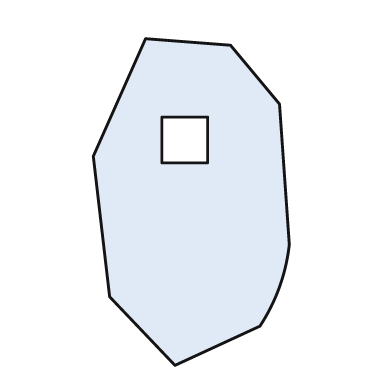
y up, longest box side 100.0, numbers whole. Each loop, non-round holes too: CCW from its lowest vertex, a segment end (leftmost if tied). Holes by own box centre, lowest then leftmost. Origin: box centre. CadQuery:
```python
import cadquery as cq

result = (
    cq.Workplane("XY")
    .moveTo(-5.0, -50.0)
    .lineTo(21.0, -38.0)
    .threePointArc((27.0, -26.0), (30.0, -13.0))
    .lineTo(27.0, 30.0)
    .lineTo(12.0, 48.0)
    .lineTo(-14.0, 50.0)
    .lineTo(-30.0, 14.0)
    .lineTo(-25.0, -29.0)
    .close()
    .moveTo(-9.0, 12.0)
    .lineTo(5.0, 12.0)
    .lineTo(5.0, 26.0)
    .lineTo(-9.0, 26.0)
    .close()
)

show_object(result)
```